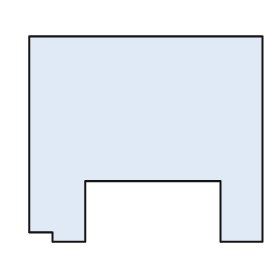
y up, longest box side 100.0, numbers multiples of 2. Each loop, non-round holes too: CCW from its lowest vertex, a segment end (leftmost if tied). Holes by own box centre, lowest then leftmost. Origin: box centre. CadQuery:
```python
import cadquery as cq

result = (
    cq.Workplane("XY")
    .moveTo(-40.0, -44.0)
    .lineTo(-26.0, -44.0)
    .lineTo(-26.0, -18.0)
    .lineTo(32.0, -18.0)
    .lineTo(32.0, -44.0)
    .lineTo(50.0, -44.0)
    .lineTo(50.0, 44.0)
    .lineTo(-50.0, 44.0)
    .lineTo(-50.0, -40.0)
    .lineTo(-40.0, -40.0)
    .close()
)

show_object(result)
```